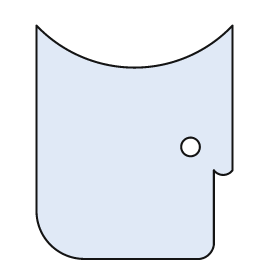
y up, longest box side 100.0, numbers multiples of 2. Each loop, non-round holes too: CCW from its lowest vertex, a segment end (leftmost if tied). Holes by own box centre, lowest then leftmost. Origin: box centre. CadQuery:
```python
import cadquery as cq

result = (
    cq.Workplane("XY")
    .moveTo(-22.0, -50.0)
    .lineTo(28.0, -50.0)
    .threePointArc((32.0, -48.0), (34.0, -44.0))
    .lineTo(34.0, -12.0)
    .threePointArc((38.0, -14.0), (42.0, -12.0))
    .lineTo(42.0, 50.0)
    .threePointArc((0.0, 32.0), (-42.0, 50.0))
    .lineTo(-42.0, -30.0)
    .threePointArc((-36.0, -44.0), (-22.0, -50.0))
    .close()
    .moveTo(24.0, -2.0)
    .circle(4.0)
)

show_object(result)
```